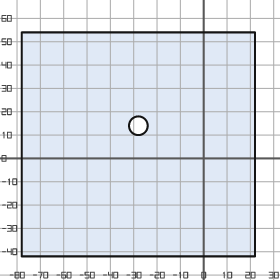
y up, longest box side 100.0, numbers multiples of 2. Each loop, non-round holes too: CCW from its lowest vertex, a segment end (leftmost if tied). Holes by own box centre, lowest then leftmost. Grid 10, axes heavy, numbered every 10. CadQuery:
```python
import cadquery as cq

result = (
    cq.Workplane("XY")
    .moveTo(-78.0, -42.0)
    .lineTo(22.0, -42.0)
    .lineTo(22.0, 54.0)
    .lineTo(-78.0, 54.0)
    .close()
    .moveTo(-28.0, 14.0)
    .circle(4.0)
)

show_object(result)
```